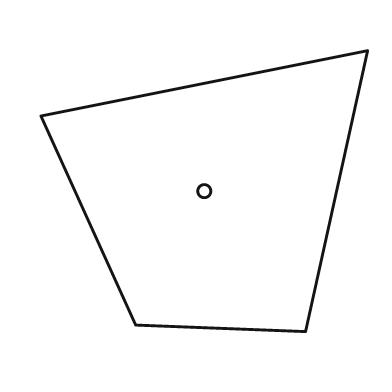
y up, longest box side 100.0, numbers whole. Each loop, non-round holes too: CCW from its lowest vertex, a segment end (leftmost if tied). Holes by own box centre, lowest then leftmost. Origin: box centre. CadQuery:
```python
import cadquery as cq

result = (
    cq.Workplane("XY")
    .moveTo(31.0, -43.0)
    .lineTo(50.0, 43.0)
    .lineTo(-50.0, 23.0)
    .lineTo(-21.0, -41.0)
    .close()
    .moveTo(0.0, 0.0)
    .circle(2.0)
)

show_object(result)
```